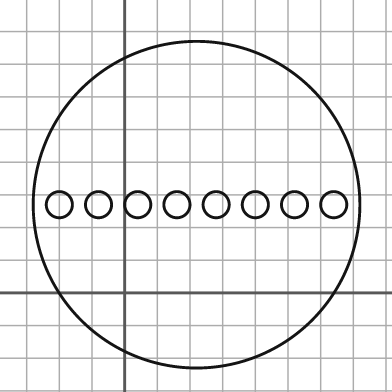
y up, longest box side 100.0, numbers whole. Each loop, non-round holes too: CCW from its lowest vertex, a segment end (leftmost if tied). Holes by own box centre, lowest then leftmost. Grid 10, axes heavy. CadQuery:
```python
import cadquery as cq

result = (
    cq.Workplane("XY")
    .moveTo(22.0, 27.0)
    .circle(50.0)
    .moveTo(-20.0, 27.0)
    .circle(4.0)
    .moveTo(-8.0, 27.0)
    .circle(4.0)
    .moveTo(4.0, 27.0)
    .circle(4.0)
    .moveTo(16.0, 27.0)
    .circle(4.0)
    .moveTo(28.0, 27.0)
    .circle(4.0)
    .moveTo(40.0, 27.0)
    .circle(4.0)
    .moveTo(52.0, 27.0)
    .circle(4.0)
    .moveTo(64.0, 27.0)
    .circle(4.0)
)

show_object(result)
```